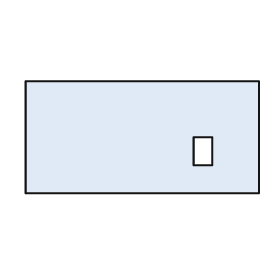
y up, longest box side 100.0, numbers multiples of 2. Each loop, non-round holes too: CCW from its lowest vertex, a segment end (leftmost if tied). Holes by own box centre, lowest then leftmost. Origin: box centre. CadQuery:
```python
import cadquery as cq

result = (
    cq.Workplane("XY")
    .moveTo(-50.0, -24.0)
    .lineTo(50.0, -24.0)
    .lineTo(50.0, 24.0)
    .lineTo(-50.0, 24.0)
    .close()
    .moveTo(22.0, -12.0)
    .lineTo(30.0, -12.0)
    .lineTo(30.0, 0.0)
    .lineTo(22.0, 0.0)
    .close()
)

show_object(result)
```